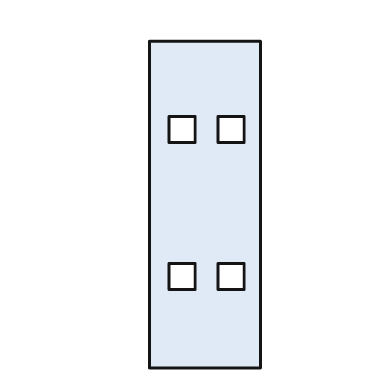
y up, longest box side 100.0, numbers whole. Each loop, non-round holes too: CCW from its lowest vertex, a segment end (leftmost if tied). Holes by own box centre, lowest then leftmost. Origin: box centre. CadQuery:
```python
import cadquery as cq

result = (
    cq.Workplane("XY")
    .moveTo(-17.0, -50.0)
    .lineTo(17.0, -50.0)
    .lineTo(17.0, 50.0)
    .lineTo(-17.0, 50.0)
    .close()
    .moveTo(-11.0, -26.0)
    .lineTo(-3.0, -26.0)
    .lineTo(-3.0, -18.0)
    .lineTo(-11.0, -18.0)
    .close()
    .moveTo(4.0, -26.0)
    .lineTo(12.0, -26.0)
    .lineTo(12.0, -18.0)
    .lineTo(4.0, -18.0)
    .close()
    .moveTo(-11.0, 19.0)
    .lineTo(-3.0, 19.0)
    .lineTo(-3.0, 27.0)
    .lineTo(-11.0, 27.0)
    .close()
    .moveTo(4.0, 19.0)
    .lineTo(12.0, 19.0)
    .lineTo(12.0, 27.0)
    .lineTo(4.0, 27.0)
    .close()
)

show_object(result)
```